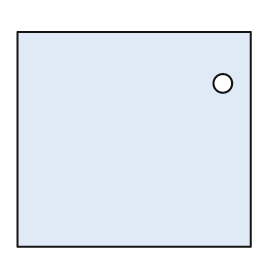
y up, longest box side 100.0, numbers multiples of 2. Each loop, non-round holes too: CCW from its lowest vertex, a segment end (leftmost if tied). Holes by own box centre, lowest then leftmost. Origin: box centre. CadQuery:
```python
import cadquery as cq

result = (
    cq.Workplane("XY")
    .moveTo(-50.0, -46.0)
    .lineTo(50.0, -46.0)
    .lineTo(50.0, 46.0)
    .lineTo(-50.0, 46.0)
    .close()
    .moveTo(38.0, 24.0)
    .circle(4.0)
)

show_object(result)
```